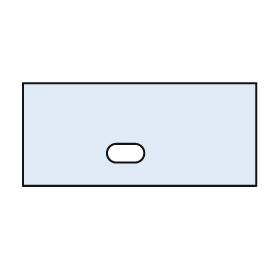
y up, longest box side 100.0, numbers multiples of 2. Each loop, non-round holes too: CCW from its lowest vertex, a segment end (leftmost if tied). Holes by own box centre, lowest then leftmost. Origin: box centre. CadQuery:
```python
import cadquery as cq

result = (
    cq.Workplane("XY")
    .moveTo(-50.0, -22.0)
    .lineTo(50.0, -22.0)
    .lineTo(50.0, 22.0)
    .lineTo(-50.0, 22.0)
    .close()
    .moveTo(-10.0, -12.0)
    .lineTo(-2.0, -12.0)
    .threePointArc((2.0, -8.0), (-2.0, -4.0))
    .lineTo(-10.0, -4.0)
    .threePointArc((-14.0, -8.0), (-10.0, -12.0))
    .close()
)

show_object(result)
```